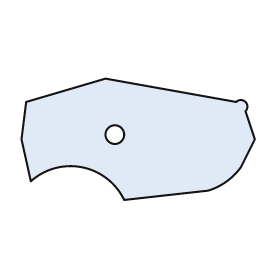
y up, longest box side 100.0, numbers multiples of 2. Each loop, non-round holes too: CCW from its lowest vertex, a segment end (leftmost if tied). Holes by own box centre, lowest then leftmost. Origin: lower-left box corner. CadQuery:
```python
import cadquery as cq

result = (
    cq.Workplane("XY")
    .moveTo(44.0, 0.0)
    .lineTo(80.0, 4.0)
    .threePointArc((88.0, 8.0), (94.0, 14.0))
    .lineTo(100.0, 26.0)
    .lineTo(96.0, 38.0)
    .threePointArc((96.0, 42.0), (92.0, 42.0))
    .lineTo(36.0, 52.0)
    .lineTo(2.0, 42.0)
    .lineTo(0.0, 26.0)
    .lineTo(4.0, 8.0)
    .threePointArc((26.0, 14.0), (44.0, 0.0))
    .close()
    .moveTo(40.0, 28.0)
    .circle(4.0)
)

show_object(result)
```